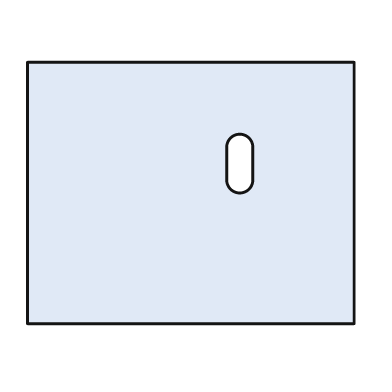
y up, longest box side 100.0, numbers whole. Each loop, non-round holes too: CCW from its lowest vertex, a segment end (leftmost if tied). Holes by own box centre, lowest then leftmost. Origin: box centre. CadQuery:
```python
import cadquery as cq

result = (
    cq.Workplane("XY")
    .moveTo(-50.0, -40.0)
    .lineTo(50.0, -40.0)
    .lineTo(50.0, 40.0)
    .lineTo(-50.0, 40.0)
    .close()
    .moveTo(11.0, 4.0)
    .threePointArc((15.0, 0.0), (19.0, 4.0))
    .lineTo(19.0, 14.0)
    .threePointArc((15.0, 18.0), (11.0, 14.0))
    .close()
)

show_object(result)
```